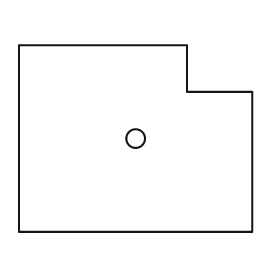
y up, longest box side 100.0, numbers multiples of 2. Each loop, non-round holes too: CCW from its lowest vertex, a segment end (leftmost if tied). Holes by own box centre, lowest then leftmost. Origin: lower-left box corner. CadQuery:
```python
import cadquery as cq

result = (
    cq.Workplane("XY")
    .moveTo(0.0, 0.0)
    .lineTo(100.0, 0.0)
    .lineTo(100.0, 60.0)
    .lineTo(72.0, 60.0)
    .lineTo(72.0, 80.0)
    .lineTo(0.0, 80.0)
    .close()
    .moveTo(50.0, 40.0)
    .circle(4.0)
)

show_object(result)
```